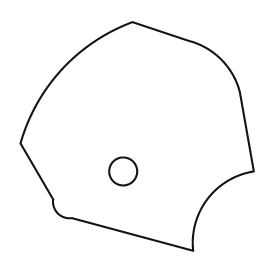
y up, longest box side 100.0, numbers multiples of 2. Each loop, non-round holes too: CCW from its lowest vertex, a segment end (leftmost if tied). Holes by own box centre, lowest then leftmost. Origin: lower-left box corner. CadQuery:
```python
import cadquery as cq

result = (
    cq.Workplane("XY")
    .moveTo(74.0, 0.0)
    .threePointArc((80.0, 22.0), (100.0, 34.0))
    .lineTo(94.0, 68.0)
    .threePointArc((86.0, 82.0), (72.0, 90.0))
    .lineTo(48.0, 98.0)
    .threePointArc((18.0, 78.0), (0.0, 46.0))
    .lineTo(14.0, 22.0)
    .threePointArc((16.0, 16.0), (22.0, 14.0))
    .close()
    .moveTo(44.0, 34.0)
    .circle(6.0)
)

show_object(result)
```